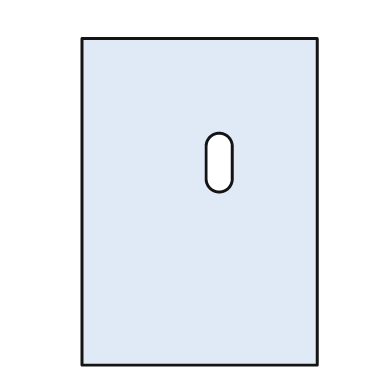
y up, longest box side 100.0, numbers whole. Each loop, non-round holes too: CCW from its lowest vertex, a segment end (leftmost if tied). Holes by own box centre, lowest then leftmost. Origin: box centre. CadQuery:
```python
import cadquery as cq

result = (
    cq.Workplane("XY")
    .moveTo(-36.0, -50.0)
    .lineTo(36.0, -50.0)
    .lineTo(36.0, 50.0)
    .lineTo(-36.0, 50.0)
    .close()
    .moveTo(2.0, 7.0)
    .threePointArc((6.0, 3.0), (10.0, 7.0))
    .lineTo(10.0, 17.0)
    .threePointArc((6.0, 21.0), (2.0, 17.0))
    .close()
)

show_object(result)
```